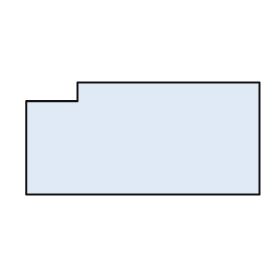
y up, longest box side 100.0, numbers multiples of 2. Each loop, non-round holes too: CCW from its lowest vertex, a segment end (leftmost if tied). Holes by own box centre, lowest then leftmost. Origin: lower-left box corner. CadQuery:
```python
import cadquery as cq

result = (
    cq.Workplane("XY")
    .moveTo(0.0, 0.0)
    .lineTo(100.0, 0.0)
    .lineTo(100.0, 48.0)
    .lineTo(22.0, 48.0)
    .lineTo(22.0, 40.0)
    .lineTo(0.0, 40.0)
    .close()
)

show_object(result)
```